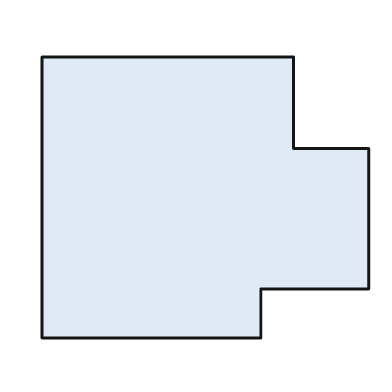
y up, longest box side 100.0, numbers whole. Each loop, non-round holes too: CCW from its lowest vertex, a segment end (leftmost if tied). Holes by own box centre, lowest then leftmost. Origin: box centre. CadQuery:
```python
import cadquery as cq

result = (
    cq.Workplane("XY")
    .moveTo(-50.0, -43.0)
    .lineTo(17.0, -43.0)
    .lineTo(17.0, -28.0)
    .lineTo(50.0, -28.0)
    .lineTo(50.0, 15.0)
    .lineTo(27.0, 15.0)
    .lineTo(27.0, 43.0)
    .lineTo(-50.0, 43.0)
    .close()
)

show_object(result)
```